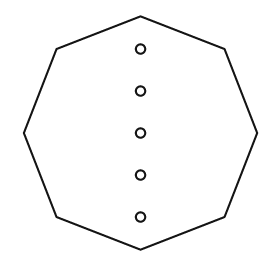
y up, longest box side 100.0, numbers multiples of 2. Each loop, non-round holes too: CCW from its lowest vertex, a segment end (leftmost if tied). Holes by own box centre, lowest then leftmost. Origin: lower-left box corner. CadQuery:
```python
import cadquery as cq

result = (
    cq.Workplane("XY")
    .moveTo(50.0, 0.0)
    .lineTo(86.0, 14.0)
    .lineTo(100.0, 50.0)
    .lineTo(86.0, 86.0)
    .lineTo(50.0, 100.0)
    .lineTo(14.0, 86.0)
    .lineTo(0.0, 50.0)
    .lineTo(14.0, 14.0)
    .close()
    .moveTo(50.0, 14.0)
    .circle(2.0)
    .moveTo(50.0, 32.0)
    .circle(2.0)
    .moveTo(50.0, 50.0)
    .circle(2.0)
    .moveTo(50.0, 68.0)
    .circle(2.0)
    .moveTo(50.0, 86.0)
    .circle(2.0)
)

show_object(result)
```